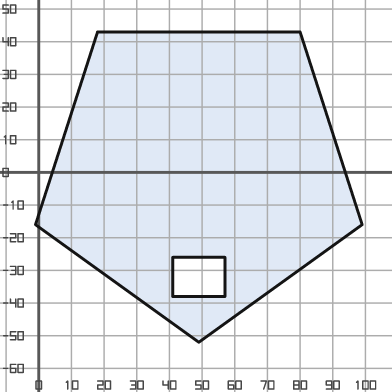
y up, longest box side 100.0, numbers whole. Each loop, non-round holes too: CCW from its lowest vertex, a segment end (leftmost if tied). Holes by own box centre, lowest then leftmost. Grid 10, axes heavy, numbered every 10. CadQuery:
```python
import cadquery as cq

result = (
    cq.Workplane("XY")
    .moveTo(49.0, -52.0)
    .lineTo(99.0, -16.0)
    .lineTo(80.0, 43.0)
    .lineTo(18.0, 43.0)
    .lineTo(-1.0, -16.0)
    .close()
    .moveTo(41.0, -38.0)
    .lineTo(57.0, -38.0)
    .lineTo(57.0, -26.0)
    .lineTo(41.0, -26.0)
    .close()
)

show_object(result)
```